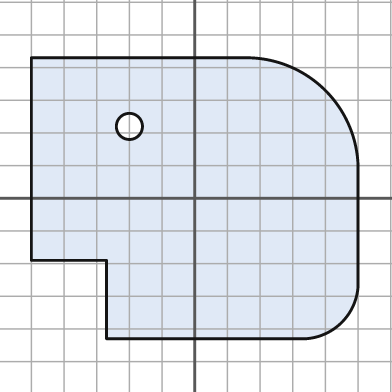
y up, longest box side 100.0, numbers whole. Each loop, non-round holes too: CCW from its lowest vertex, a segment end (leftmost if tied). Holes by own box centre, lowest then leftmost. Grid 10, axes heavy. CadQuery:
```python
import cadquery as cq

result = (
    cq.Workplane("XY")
    .moveTo(-27.0, -43.0)
    .lineTo(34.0, -43.0)
    .threePointArc((45.0, -38.0), (50.0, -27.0))
    .lineTo(50.0, 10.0)
    .threePointArc((40.0, 33.0), (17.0, 43.0))
    .lineTo(-50.0, 43.0)
    .lineTo(-50.0, -19.0)
    .lineTo(-27.0, -19.0)
    .close()
    .moveTo(-20.0, 22.0)
    .circle(4.0)
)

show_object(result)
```